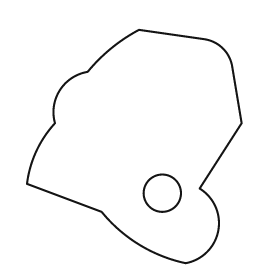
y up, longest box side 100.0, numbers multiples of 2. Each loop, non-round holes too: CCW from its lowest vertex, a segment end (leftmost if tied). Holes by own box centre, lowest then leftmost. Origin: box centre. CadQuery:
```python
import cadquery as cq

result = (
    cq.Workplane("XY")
    .moveTo(22.0, -50.0)
    .threePointArc((36.0, -36.0), (28.0, -18.0))
    .lineTo(46.0, 10.0)
    .lineTo(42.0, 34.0)
    .threePointArc((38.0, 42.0), (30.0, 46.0))
    .lineTo(2.0, 50.0)
    .threePointArc((-10.0, 42.0), (-20.0, 32.0))
    .threePointArc((-32.0, 24.0), (-34.0, 10.0))
    .threePointArc((-42.0, -2.0), (-46.0, -16.0))
    .lineTo(-14.0, -28.0)
    .threePointArc((2.0, -42.0), (22.0, -50.0))
    .close()
    .moveTo(12.0, -20.0)
    .circle(8.0)
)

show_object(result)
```